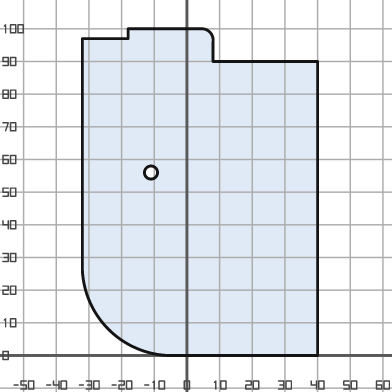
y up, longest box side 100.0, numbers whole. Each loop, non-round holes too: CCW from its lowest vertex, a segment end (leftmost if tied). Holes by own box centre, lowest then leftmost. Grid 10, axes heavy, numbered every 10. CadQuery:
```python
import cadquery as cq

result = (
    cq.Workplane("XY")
    .moveTo(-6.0, 0.0)
    .lineTo(40.0, 0.0)
    .lineTo(40.0, 90.0)
    .lineTo(8.0, 90.0)
    .lineTo(8.0, 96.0)
    .threePointArc((7.0, 99.0), (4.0, 100.0))
    .lineTo(-18.0, 100.0)
    .lineTo(-18.0, 97.0)
    .lineTo(-32.0, 97.0)
    .lineTo(-32.0, 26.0)
    .threePointArc((-24.0, 8.0), (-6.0, 0.0))
    .close()
    .moveTo(-11.0, 56.0)
    .circle(2.0)
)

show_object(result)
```